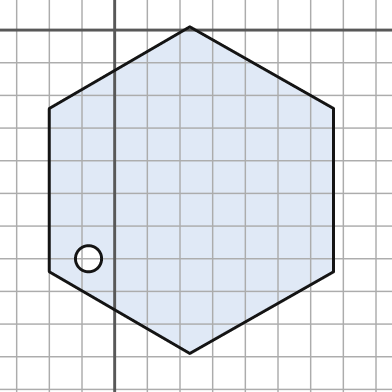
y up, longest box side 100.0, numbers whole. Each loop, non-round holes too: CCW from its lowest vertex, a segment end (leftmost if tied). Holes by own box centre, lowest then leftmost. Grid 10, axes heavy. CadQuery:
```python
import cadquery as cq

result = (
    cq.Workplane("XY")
    .moveTo(23.0, -99.0)
    .lineTo(67.0, -74.0)
    .lineTo(67.0, -24.0)
    .lineTo(23.0, 1.0)
    .lineTo(-20.0, -24.0)
    .lineTo(-20.0, -74.0)
    .close()
    .moveTo(-8.0, -70.0)
    .circle(4.0)
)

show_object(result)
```